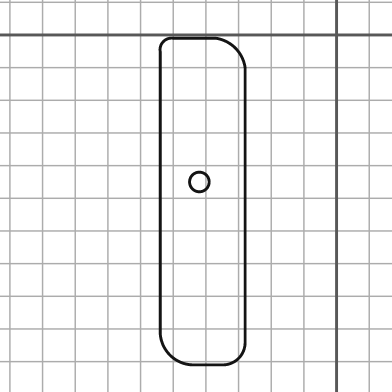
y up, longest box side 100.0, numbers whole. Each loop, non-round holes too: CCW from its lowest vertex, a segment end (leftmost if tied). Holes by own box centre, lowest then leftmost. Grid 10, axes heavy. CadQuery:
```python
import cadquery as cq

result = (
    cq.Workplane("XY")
    .moveTo(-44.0, -101.0)
    .lineTo(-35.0, -101.0)
    .threePointArc((-30.0, -99.0), (-28.0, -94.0))
    .lineTo(-28.0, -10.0)
    .threePointArc((-31.0, -4.0), (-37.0, -1.0))
    .lineTo(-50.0, -1.0)
    .threePointArc((-53.0, -2.0), (-54.0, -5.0))
    .lineTo(-54.0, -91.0)
    .threePointArc((-51.0, -98.0), (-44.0, -101.0))
    .close()
    .moveTo(-42.0, -45.0)
    .circle(3.0)
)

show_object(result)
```